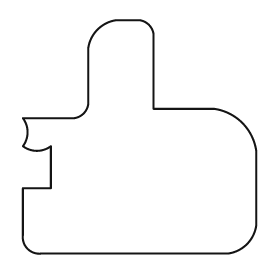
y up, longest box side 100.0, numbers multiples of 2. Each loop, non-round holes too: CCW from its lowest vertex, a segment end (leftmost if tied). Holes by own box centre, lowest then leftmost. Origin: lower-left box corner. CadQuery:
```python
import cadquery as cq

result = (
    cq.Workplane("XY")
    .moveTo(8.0, 0.0)
    .lineTo(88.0, 0.0)
    .threePointArc((96.0, 4.0), (100.0, 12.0))
    .lineTo(100.0, 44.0)
    .threePointArc((94.0, 56.0), (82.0, 62.0))
    .lineTo(56.0, 62.0)
    .lineTo(56.0, 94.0)
    .threePointArc((54.0, 98.0), (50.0, 100.0))
    .lineTo(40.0, 100.0)
    .threePointArc((32.0, 96.0), (28.0, 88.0))
    .lineTo(28.0, 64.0)
    .threePointArc((26.0, 60.0), (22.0, 58.0))
    .lineTo(0.0, 58.0)
    .threePointArc((2.0, 52.0), (0.0, 46.0))
    .threePointArc((6.0, 44.0), (12.0, 46.0))
    .lineTo(12.0, 28.0)
    .lineTo(0.0, 28.0)
    .lineTo(0.0, 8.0)
    .threePointArc((2.0, 2.0), (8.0, 0.0))
    .close()
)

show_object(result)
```